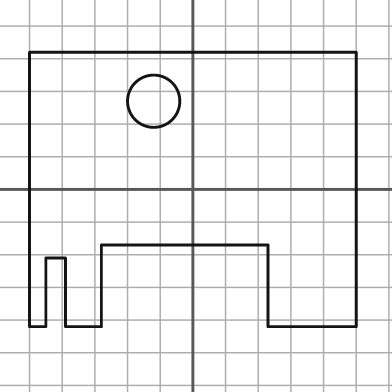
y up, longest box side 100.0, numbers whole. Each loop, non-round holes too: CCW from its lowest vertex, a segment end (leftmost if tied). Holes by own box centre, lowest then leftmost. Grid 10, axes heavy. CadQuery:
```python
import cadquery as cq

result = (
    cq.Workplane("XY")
    .moveTo(-50.0, -42.0)
    .lineTo(-45.0, -42.0)
    .lineTo(-45.0, -21.0)
    .lineTo(-39.0, -21.0)
    .lineTo(-39.0, -42.0)
    .lineTo(-28.0, -42.0)
    .lineTo(-28.0, -17.0)
    .lineTo(23.0, -17.0)
    .lineTo(23.0, -42.0)
    .lineTo(50.0, -42.0)
    .lineTo(50.0, 42.0)
    .lineTo(-50.0, 42.0)
    .close()
    .moveTo(-12.0, 27.0)
    .circle(8.0)
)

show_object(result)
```